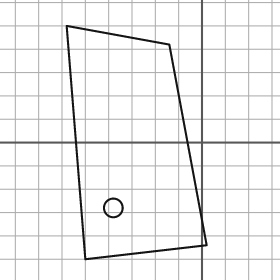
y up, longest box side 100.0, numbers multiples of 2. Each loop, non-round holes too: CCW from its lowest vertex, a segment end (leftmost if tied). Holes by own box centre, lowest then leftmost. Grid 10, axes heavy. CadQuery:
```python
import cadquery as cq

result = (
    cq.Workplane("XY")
    .moveTo(-50.0, -50.0)
    .lineTo(2.0, -44.0)
    .lineTo(-14.0, 42.0)
    .lineTo(-58.0, 50.0)
    .close()
    .moveTo(-38.0, -28.0)
    .circle(4.0)
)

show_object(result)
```